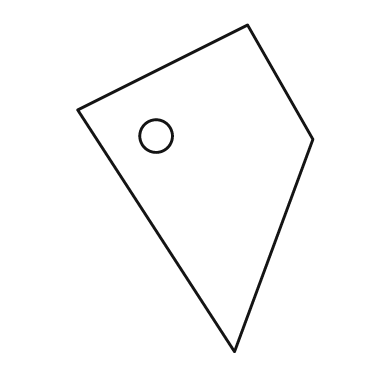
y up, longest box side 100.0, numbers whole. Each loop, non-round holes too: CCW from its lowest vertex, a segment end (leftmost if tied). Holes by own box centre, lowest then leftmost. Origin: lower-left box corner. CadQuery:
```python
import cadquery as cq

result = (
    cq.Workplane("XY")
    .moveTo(48.0, 0.0)
    .lineTo(72.0, 65.0)
    .lineTo(52.0, 100.0)
    .lineTo(0.0, 74.0)
    .close()
    .moveTo(24.0, 66.0)
    .circle(5.0)
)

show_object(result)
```